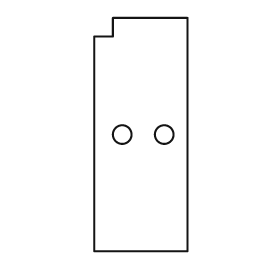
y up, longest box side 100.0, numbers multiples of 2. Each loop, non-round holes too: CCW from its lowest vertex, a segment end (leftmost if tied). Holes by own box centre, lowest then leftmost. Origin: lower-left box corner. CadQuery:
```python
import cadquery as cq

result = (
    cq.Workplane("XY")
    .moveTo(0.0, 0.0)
    .lineTo(40.0, 0.0)
    .lineTo(40.0, 100.0)
    .lineTo(8.0, 100.0)
    .lineTo(8.0, 92.0)
    .lineTo(0.0, 92.0)
    .close()
    .moveTo(12.0, 50.0)
    .circle(4.0)
    .moveTo(30.0, 50.0)
    .circle(4.0)
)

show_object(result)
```